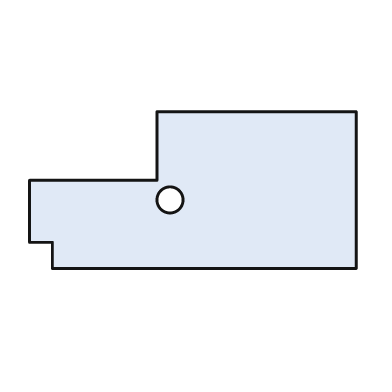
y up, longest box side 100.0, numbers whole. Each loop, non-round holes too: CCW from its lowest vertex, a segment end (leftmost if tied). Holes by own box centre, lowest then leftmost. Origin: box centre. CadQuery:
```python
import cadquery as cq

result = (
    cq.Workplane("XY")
    .moveTo(-43.0, -24.0)
    .lineTo(50.0, -24.0)
    .lineTo(50.0, 24.0)
    .lineTo(-11.0, 24.0)
    .lineTo(-11.0, 3.0)
    .lineTo(-50.0, 3.0)
    .lineTo(-50.0, -16.0)
    .lineTo(-43.0, -16.0)
    .close()
    .moveTo(-7.0, -3.0)
    .circle(4.0)
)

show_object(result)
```